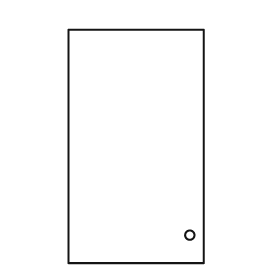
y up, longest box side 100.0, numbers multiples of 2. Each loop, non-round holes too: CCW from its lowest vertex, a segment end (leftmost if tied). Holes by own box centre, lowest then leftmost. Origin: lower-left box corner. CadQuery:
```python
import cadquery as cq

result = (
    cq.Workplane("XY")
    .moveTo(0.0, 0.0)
    .lineTo(58.0, 0.0)
    .lineTo(58.0, 100.0)
    .lineTo(0.0, 100.0)
    .close()
    .moveTo(52.0, 12.0)
    .circle(2.0)
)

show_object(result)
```